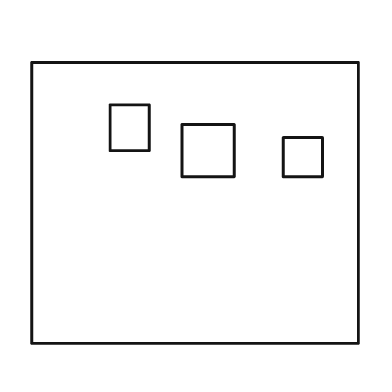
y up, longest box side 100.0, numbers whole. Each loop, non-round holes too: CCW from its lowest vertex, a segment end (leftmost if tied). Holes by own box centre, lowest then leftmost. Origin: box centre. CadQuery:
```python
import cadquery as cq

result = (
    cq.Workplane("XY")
    .moveTo(-50.0, -43.0)
    .lineTo(50.0, -43.0)
    .lineTo(50.0, 43.0)
    .lineTo(-50.0, 43.0)
    .close()
    .moveTo(27.0, 8.0)
    .lineTo(39.0, 8.0)
    .lineTo(39.0, 20.0)
    .lineTo(27.0, 20.0)
    .close()
    .moveTo(-4.0, 8.0)
    .lineTo(12.0, 8.0)
    .lineTo(12.0, 24.0)
    .lineTo(-4.0, 24.0)
    .close()
    .moveTo(-26.0, 16.0)
    .lineTo(-14.0, 16.0)
    .lineTo(-14.0, 30.0)
    .lineTo(-26.0, 30.0)
    .close()
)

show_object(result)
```